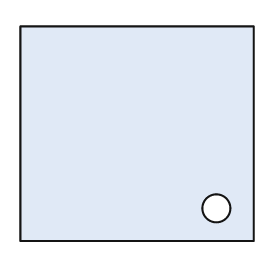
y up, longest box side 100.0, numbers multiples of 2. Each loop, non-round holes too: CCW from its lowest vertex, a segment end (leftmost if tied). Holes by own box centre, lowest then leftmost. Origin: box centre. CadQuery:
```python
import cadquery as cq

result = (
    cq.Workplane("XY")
    .moveTo(-50.0, -46.0)
    .lineTo(50.0, -46.0)
    .lineTo(50.0, 46.0)
    .lineTo(-50.0, 46.0)
    .close()
    .moveTo(34.0, -32.0)
    .circle(6.0)
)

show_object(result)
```